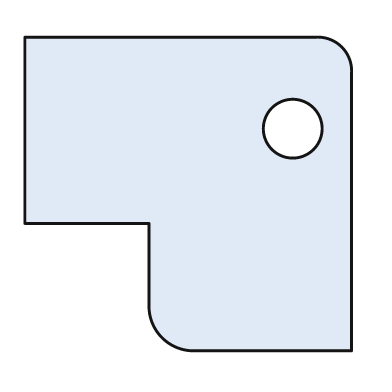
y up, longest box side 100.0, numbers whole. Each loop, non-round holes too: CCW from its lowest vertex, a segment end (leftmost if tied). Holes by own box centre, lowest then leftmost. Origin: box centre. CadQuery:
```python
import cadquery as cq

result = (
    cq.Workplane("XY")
    .moveTo(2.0, -48.0)
    .lineTo(50.0, -48.0)
    .lineTo(50.0, 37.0)
    .threePointArc((47.0, 45.0), (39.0, 48.0))
    .lineTo(-50.0, 48.0)
    .lineTo(-50.0, -9.0)
    .lineTo(-12.0, -9.0)
    .lineTo(-12.0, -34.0)
    .threePointArc((-8.0, -44.0), (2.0, -48.0))
    .close()
    .moveTo(32.0, 20.0)
    .circle(9.0)
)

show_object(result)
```